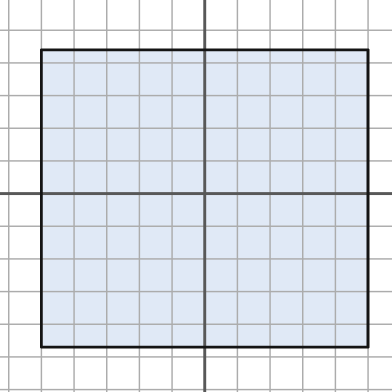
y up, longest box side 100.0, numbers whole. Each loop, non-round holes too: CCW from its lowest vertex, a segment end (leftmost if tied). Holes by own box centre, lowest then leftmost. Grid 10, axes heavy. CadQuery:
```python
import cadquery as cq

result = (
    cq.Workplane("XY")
    .moveTo(-50.0, -47.0)
    .lineTo(50.0, -47.0)
    .lineTo(50.0, 44.0)
    .lineTo(-50.0, 44.0)
    .close()
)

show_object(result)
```